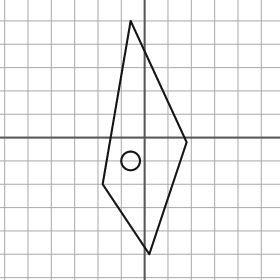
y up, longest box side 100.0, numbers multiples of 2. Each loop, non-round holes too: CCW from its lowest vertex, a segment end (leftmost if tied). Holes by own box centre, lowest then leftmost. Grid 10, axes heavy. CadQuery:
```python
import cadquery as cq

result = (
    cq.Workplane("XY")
    .moveTo(2.0, -50.0)
    .lineTo(18.0, -2.0)
    .lineTo(-6.0, 50.0)
    .lineTo(-18.0, -20.0)
    .close()
    .moveTo(-6.0, -10.0)
    .circle(4.0)
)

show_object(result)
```